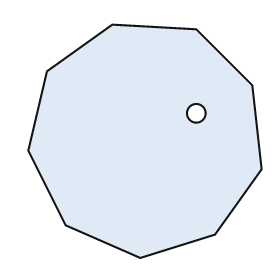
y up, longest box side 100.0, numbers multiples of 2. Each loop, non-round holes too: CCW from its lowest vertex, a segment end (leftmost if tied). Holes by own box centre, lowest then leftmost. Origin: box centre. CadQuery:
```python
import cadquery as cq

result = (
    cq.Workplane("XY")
    .moveTo(-2.0, -50.0)
    .lineTo(30.0, -40.0)
    .lineTo(50.0, -12.0)
    .lineTo(46.0, 24.0)
    .lineTo(22.0, 48.0)
    .lineTo(-14.0, 50.0)
    .lineTo(-42.0, 30.0)
    .lineTo(-50.0, -4.0)
    .lineTo(-34.0, -36.0)
    .close()
    .moveTo(22.0, 12.0)
    .circle(4.0)
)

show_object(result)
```